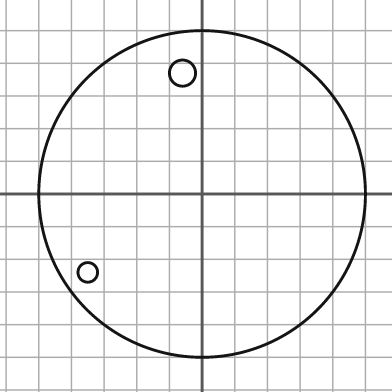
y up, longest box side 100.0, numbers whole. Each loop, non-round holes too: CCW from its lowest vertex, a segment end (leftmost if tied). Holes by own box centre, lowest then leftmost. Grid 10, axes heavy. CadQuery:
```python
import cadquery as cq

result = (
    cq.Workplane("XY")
    .moveTo(0.0, 0.0)
    .circle(50.0)
    .moveTo(-35.0, -24.0)
    .circle(3.0)
    .moveTo(-6.0, 37.0)
    .circle(4.0)
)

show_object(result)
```